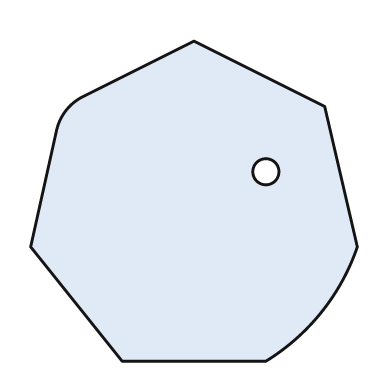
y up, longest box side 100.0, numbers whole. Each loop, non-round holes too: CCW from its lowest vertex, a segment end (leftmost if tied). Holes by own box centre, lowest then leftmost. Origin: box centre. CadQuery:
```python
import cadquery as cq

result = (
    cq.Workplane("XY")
    .moveTo(-22.0, -49.0)
    .lineTo(22.0, -49.0)
    .threePointArc((39.0, -34.0), (50.0, -14.0))
    .lineTo(40.0, 29.0)
    .lineTo(0.0, 49.0)
    .lineTo(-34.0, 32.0)
    .threePointArc((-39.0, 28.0), (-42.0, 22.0))
    .lineTo(-50.0, -14.0)
    .close()
    .moveTo(22.0, 9.0)
    .circle(4.0)
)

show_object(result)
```